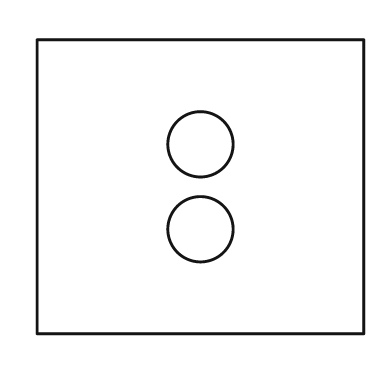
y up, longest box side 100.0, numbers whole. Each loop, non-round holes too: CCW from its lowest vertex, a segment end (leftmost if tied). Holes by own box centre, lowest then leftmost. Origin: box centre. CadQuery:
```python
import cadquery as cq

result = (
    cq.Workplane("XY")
    .moveTo(-50.0, -45.0)
    .lineTo(50.0, -45.0)
    .lineTo(50.0, 45.0)
    .lineTo(-50.0, 45.0)
    .close()
    .moveTo(0.0, -13.0)
    .circle(10.0)
    .moveTo(0.0, 13.0)
    .circle(10.0)
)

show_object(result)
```